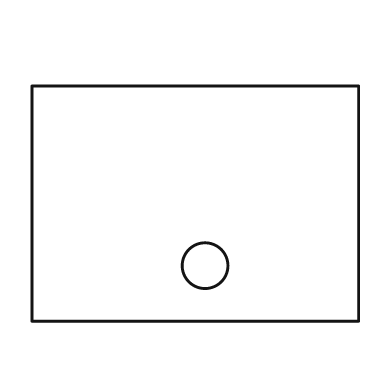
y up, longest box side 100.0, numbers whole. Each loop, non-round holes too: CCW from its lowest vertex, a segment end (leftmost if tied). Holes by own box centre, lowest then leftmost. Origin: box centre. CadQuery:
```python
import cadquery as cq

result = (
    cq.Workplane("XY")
    .moveTo(-50.0, -36.0)
    .lineTo(50.0, -36.0)
    .lineTo(50.0, 36.0)
    .lineTo(-50.0, 36.0)
    .close()
    .moveTo(3.0, -19.0)
    .circle(7.0)
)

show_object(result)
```